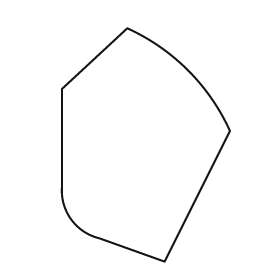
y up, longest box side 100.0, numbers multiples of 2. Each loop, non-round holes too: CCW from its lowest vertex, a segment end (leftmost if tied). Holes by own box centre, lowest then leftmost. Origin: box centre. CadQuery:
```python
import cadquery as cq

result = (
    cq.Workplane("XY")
    .moveTo(8.0, -50.0)
    .lineTo(36.0, 6.0)
    .threePointArc((18.0, 32.0), (-8.0, 50.0))
    .lineTo(-36.0, 24.0)
    .lineTo(-36.0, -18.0)
    .threePointArc((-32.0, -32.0), (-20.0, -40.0))
    .close()
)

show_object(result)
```